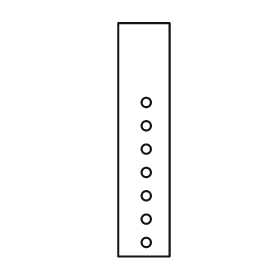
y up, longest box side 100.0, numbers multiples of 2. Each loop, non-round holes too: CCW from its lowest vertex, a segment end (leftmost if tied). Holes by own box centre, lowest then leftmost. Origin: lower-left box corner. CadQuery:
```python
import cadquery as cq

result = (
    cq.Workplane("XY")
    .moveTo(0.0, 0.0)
    .lineTo(22.0, 0.0)
    .lineTo(22.0, 100.0)
    .lineTo(0.0, 100.0)
    .close()
    .moveTo(12.0, 6.0)
    .circle(2.0)
    .moveTo(12.0, 16.0)
    .circle(2.0)
    .moveTo(12.0, 26.0)
    .circle(2.0)
    .moveTo(12.0, 36.0)
    .circle(2.0)
    .moveTo(12.0, 46.0)
    .circle(2.0)
    .moveTo(12.0, 56.0)
    .circle(2.0)
    .moveTo(12.0, 66.0)
    .circle(2.0)
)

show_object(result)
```